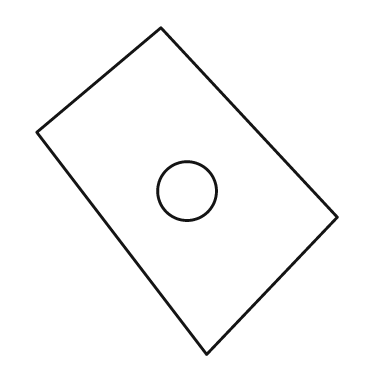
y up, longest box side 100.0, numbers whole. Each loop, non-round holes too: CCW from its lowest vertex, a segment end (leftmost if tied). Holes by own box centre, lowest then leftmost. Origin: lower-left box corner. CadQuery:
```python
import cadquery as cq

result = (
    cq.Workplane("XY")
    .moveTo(52.0, 0.0)
    .lineTo(92.0, 42.0)
    .lineTo(38.0, 100.0)
    .lineTo(0.0, 68.0)
    .close()
    .moveTo(46.0, 50.0)
    .circle(9.0)
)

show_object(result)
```